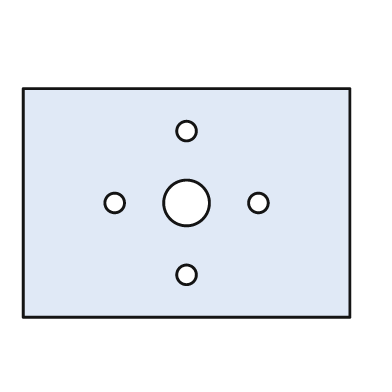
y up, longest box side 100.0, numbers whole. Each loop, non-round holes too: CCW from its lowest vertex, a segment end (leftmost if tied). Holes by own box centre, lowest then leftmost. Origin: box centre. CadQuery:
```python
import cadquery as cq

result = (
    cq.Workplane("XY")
    .moveTo(-50.0, -35.0)
    .lineTo(50.0, -35.0)
    .lineTo(50.0, 35.0)
    .lineTo(-50.0, 35.0)
    .close()
    .moveTo(0.0, -22.0)
    .circle(3.0)
    .moveTo(-22.0, 0.0)
    .circle(3.0)
    .moveTo(0.0, 0.0)
    .circle(7.0)
    .moveTo(22.0, 0.0)
    .circle(3.0)
    .moveTo(0.0, 22.0)
    .circle(3.0)
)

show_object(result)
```